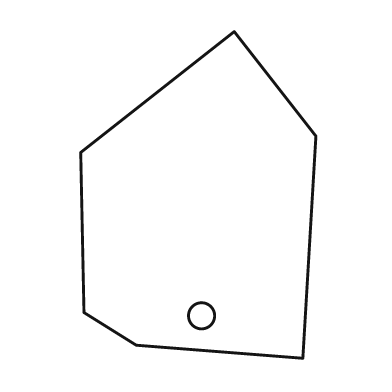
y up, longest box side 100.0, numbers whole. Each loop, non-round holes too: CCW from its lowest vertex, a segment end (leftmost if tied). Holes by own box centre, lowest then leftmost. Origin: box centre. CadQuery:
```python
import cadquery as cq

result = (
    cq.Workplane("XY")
    .moveTo(32.0, -50.0)
    .lineTo(36.0, 18.0)
    .lineTo(11.0, 50.0)
    .lineTo(-36.0, 13.0)
    .lineTo(-35.0, -36.0)
    .lineTo(-19.0, -46.0)
    .close()
    .moveTo(1.0, -37.0)
    .circle(4.0)
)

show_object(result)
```